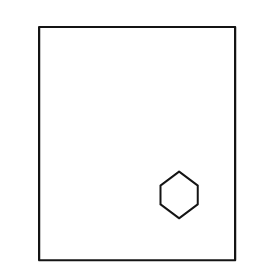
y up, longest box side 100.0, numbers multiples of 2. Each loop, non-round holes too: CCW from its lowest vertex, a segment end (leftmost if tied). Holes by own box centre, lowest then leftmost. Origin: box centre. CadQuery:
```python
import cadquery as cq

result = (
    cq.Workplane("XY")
    .moveTo(-42.0, -50.0)
    .lineTo(42.0, -50.0)
    .lineTo(42.0, 50.0)
    .lineTo(-42.0, 50.0)
    .close()
    .moveTo(18.0, -32.0)
    .lineTo(26.0, -26.0)
    .lineTo(26.0, -18.0)
    .lineTo(18.0, -12.0)
    .lineTo(10.0, -18.0)
    .lineTo(10.0, -26.0)
    .close()
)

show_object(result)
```